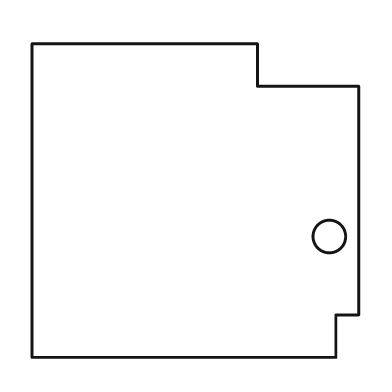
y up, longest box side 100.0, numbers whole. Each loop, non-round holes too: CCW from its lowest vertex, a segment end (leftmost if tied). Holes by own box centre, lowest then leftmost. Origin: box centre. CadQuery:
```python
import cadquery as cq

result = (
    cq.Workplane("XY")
    .moveTo(-50.0, -48.0)
    .lineTo(43.0, -48.0)
    .lineTo(43.0, -35.0)
    .lineTo(50.0, -35.0)
    .lineTo(50.0, 35.0)
    .lineTo(19.0, 35.0)
    .lineTo(19.0, 48.0)
    .lineTo(-50.0, 48.0)
    .close()
    .moveTo(41.0, -11.0)
    .circle(5.0)
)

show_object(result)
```